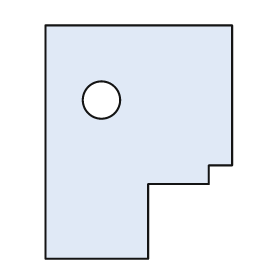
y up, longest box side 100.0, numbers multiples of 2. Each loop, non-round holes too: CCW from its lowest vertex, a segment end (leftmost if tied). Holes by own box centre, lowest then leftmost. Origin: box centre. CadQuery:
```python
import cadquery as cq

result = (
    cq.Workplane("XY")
    .moveTo(-40.0, -50.0)
    .lineTo(4.0, -50.0)
    .lineTo(4.0, -18.0)
    .lineTo(30.0, -18.0)
    .lineTo(30.0, -10.0)
    .lineTo(40.0, -10.0)
    .lineTo(40.0, 50.0)
    .lineTo(-40.0, 50.0)
    .close()
    .moveTo(-16.0, 18.0)
    .circle(8.0)
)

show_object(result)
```